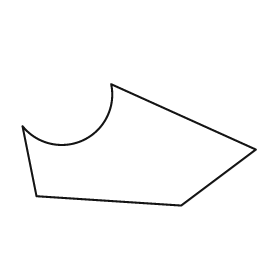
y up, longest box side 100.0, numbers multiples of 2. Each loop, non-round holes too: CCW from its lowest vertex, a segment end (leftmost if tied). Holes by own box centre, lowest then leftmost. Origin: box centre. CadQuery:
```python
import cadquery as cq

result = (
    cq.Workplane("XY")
    .moveTo(18.0, -26.0)
    .lineTo(50.0, -2.0)
    .lineTo(-12.0, 26.0)
    .threePointArc((-24.0, 2.0), (-50.0, 8.0))
    .lineTo(-44.0, -22.0)
    .close()
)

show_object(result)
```